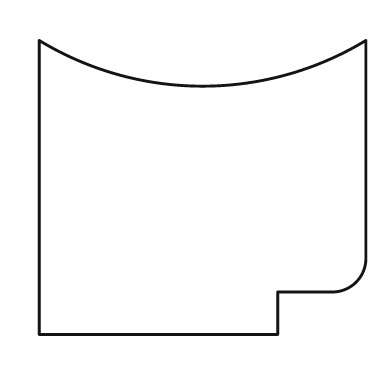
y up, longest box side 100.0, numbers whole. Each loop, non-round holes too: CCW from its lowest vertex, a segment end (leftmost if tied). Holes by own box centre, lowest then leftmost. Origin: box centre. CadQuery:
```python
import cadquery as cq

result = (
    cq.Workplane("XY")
    .moveTo(-50.0, -45.0)
    .lineTo(23.0, -45.0)
    .lineTo(23.0, -32.0)
    .lineTo(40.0, -32.0)
    .threePointArc((47.0, -29.0), (50.0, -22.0))
    .lineTo(50.0, 45.0)
    .threePointArc((0.0, 31.0), (-50.0, 45.0))
    .close()
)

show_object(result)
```